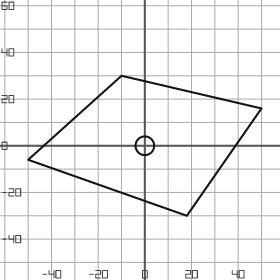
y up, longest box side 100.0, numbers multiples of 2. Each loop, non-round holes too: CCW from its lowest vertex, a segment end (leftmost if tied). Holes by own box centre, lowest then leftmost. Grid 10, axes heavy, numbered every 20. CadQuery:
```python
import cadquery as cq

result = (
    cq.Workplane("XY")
    .moveTo(18.0, -30.0)
    .lineTo(50.0, 16.0)
    .lineTo(-10.0, 30.0)
    .lineTo(-50.0, -6.0)
    .close()
    .moveTo(0.0, 0.0)
    .circle(4.0)
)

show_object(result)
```